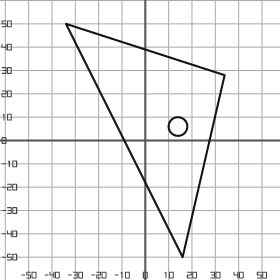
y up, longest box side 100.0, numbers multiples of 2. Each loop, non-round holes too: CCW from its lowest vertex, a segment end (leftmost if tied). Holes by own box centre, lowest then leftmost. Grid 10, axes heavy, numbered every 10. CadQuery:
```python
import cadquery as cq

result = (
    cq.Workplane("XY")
    .moveTo(16.0, -50.0)
    .lineTo(34.0, 28.0)
    .lineTo(-34.0, 50.0)
    .close()
    .moveTo(14.0, 6.0)
    .circle(4.0)
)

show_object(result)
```